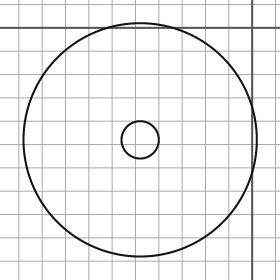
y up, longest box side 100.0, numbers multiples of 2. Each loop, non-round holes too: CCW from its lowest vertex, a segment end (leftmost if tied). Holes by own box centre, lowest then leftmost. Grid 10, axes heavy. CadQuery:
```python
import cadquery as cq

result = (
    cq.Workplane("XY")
    .moveTo(-48.0, -48.0)
    .circle(50.0)
    .moveTo(-48.0, -48.0)
    .circle(8.0)
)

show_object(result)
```